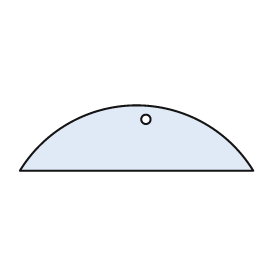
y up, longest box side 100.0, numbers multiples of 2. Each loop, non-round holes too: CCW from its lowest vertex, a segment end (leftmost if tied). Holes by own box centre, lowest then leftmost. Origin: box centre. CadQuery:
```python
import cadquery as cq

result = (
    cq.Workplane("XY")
    .moveTo(-50.0, -14.0)
    .lineTo(50.0, -14.0)
    .threePointArc((0.0, 14.0), (-50.0, -14.0))
    .close()
    .moveTo(4.0, 8.0)
    .circle(2.0)
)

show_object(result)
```